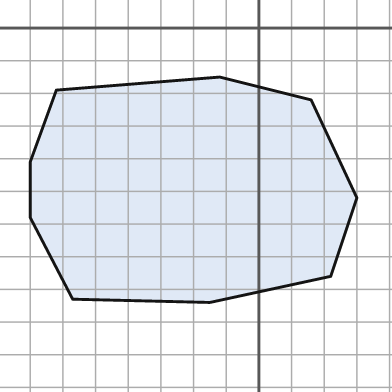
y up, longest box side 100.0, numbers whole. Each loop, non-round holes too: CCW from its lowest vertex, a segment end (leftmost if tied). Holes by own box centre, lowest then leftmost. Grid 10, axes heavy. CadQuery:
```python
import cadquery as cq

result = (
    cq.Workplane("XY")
    .moveTo(-15.0, -84.0)
    .lineTo(22.0, -76.0)
    .lineTo(30.0, -52.0)
    .lineTo(16.0, -22.0)
    .lineTo(-12.0, -15.0)
    .lineTo(-62.0, -19.0)
    .lineTo(-70.0, -41.0)
    .lineTo(-70.0, -58.0)
    .lineTo(-57.0, -83.0)
    .close()
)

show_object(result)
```